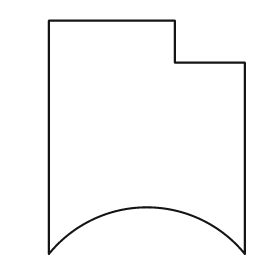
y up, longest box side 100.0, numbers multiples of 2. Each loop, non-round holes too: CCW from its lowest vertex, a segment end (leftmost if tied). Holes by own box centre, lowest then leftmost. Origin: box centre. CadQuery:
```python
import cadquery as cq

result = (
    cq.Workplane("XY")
    .moveTo(-42.0, -50.0)
    .threePointArc((0.0, -30.0), (42.0, -50.0))
    .lineTo(42.0, 32.0)
    .lineTo(12.0, 32.0)
    .lineTo(12.0, 50.0)
    .lineTo(-42.0, 50.0)
    .close()
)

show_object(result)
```